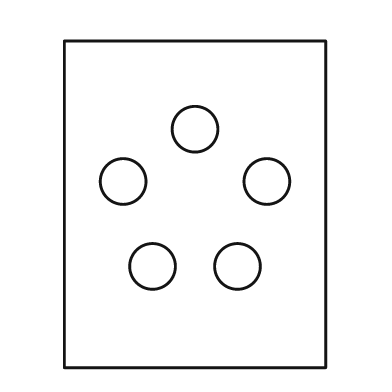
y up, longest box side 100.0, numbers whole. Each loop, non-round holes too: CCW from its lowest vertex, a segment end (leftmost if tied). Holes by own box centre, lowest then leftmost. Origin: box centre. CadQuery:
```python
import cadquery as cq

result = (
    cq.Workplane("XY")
    .moveTo(-40.0, -50.0)
    .lineTo(40.0, -50.0)
    .lineTo(40.0, 50.0)
    .lineTo(-40.0, 50.0)
    .close()
    .moveTo(-13.0, -19.0)
    .circle(7.0)
    .moveTo(13.0, -19.0)
    .circle(7.0)
    .moveTo(-22.0, 7.0)
    .circle(7.0)
    .moveTo(22.0, 7.0)
    .circle(7.0)
    .moveTo(0.0, 23.0)
    .circle(7.0)
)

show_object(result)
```